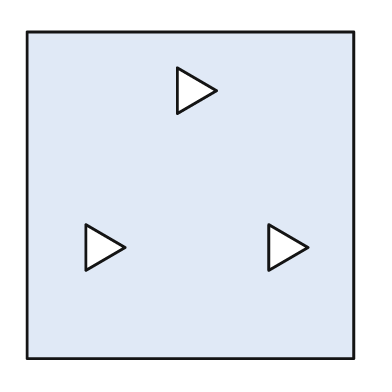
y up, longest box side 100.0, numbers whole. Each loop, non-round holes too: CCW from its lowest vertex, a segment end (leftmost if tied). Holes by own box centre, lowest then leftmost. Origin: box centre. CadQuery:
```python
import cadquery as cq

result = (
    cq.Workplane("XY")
    .moveTo(-50.0, -50.0)
    .lineTo(50.0, -50.0)
    .lineTo(50.0, 50.0)
    .lineTo(-50.0, 50.0)
    .close()
    .moveTo(-32.0, -23.0)
    .lineTo(-20.0, -16.0)
    .lineTo(-32.0, -9.0)
    .close()
    .moveTo(24.0, -23.0)
    .lineTo(36.0, -16.0)
    .lineTo(24.0, -9.0)
    .close()
    .moveTo(-4.0, 25.0)
    .lineTo(8.0, 32.0)
    .lineTo(-4.0, 39.0)
    .close()
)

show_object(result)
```